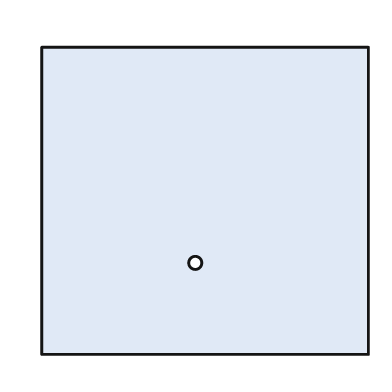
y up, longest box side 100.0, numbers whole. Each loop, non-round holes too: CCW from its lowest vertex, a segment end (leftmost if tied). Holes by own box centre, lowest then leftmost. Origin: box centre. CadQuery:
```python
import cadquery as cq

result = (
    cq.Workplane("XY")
    .moveTo(-50.0, -47.0)
    .lineTo(50.0, -47.0)
    .lineTo(50.0, 47.0)
    .lineTo(-50.0, 47.0)
    .close()
    .moveTo(-3.0, -19.0)
    .circle(2.0)
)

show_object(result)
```